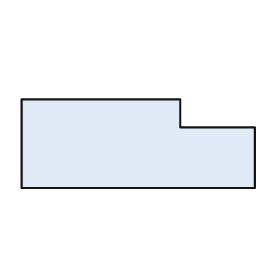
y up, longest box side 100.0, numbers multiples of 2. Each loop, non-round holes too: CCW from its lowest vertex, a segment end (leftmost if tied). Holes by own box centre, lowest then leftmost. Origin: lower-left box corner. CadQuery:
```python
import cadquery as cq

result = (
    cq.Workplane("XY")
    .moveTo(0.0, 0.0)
    .lineTo(100.0, 0.0)
    .lineTo(100.0, 26.0)
    .lineTo(68.0, 26.0)
    .lineTo(68.0, 38.0)
    .lineTo(0.0, 38.0)
    .close()
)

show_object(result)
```